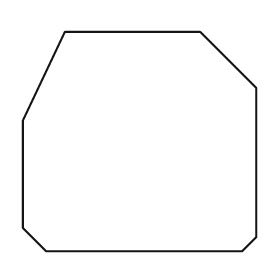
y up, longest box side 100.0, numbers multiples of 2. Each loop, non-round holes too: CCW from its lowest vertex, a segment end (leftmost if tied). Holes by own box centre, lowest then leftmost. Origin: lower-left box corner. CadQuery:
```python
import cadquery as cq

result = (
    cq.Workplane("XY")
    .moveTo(10.0, 0.0)
    .lineTo(94.0, 0.0)
    .lineTo(100.0, 6.0)
    .lineTo(100.0, 70.0)
    .lineTo(76.0, 94.0)
    .lineTo(18.0, 94.0)
    .lineTo(0.0, 56.0)
    .lineTo(0.0, 10.0)
    .close()
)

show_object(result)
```